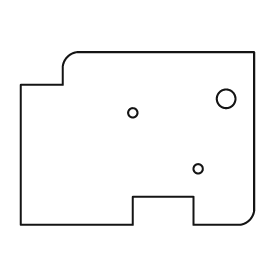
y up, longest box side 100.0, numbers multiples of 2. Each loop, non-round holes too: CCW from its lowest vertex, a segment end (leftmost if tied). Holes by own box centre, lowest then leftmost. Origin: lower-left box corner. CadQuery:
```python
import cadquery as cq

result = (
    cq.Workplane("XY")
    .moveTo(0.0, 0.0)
    .lineTo(48.0, 0.0)
    .lineTo(48.0, 12.0)
    .lineTo(74.0, 12.0)
    .lineTo(74.0, 0.0)
    .lineTo(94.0, 0.0)
    .threePointArc((98.0, 2.0), (100.0, 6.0))
    .lineTo(100.0, 74.0)
    .lineTo(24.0, 74.0)
    .threePointArc((20.0, 72.0), (18.0, 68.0))
    .lineTo(18.0, 60.0)
    .lineTo(0.0, 60.0)
    .close()
    .moveTo(76.0, 24.0)
    .circle(2.0)
    .moveTo(48.0, 48.0)
    .circle(2.0)
    .moveTo(88.0, 54.0)
    .circle(4.0)
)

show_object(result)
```